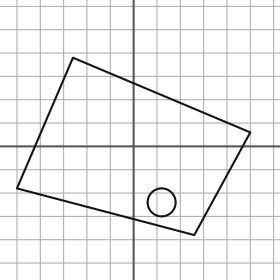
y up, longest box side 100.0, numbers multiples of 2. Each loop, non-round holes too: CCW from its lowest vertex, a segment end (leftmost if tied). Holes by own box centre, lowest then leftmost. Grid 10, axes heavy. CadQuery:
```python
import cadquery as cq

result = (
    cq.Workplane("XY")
    .moveTo(26.0, -38.0)
    .lineTo(50.0, 6.0)
    .lineTo(-26.0, 38.0)
    .lineTo(-50.0, -18.0)
    .close()
    .moveTo(12.0, -24.0)
    .circle(6.0)
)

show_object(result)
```